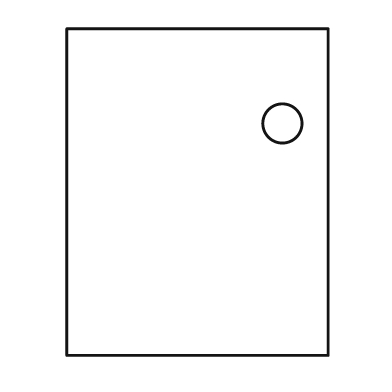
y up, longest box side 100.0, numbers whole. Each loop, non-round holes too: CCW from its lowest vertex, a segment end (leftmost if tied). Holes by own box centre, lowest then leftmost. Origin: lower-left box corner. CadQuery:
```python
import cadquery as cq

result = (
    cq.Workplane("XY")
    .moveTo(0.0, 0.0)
    .lineTo(80.0, 0.0)
    .lineTo(80.0, 100.0)
    .lineTo(0.0, 100.0)
    .close()
    .moveTo(66.0, 71.0)
    .circle(6.0)
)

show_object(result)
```